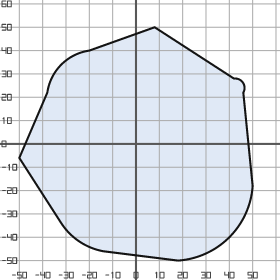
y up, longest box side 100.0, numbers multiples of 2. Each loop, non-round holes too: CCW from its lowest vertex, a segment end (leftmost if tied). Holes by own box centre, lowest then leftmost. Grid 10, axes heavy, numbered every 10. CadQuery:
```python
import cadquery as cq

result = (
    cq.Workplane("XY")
    .moveTo(18.0, -50.0)
    .threePointArc((40.0, -40.0), (50.0, -18.0))
    .lineTo(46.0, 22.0)
    .threePointArc((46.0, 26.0), (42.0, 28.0))
    .lineTo(8.0, 50.0)
    .lineTo(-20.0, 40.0)
    .threePointArc((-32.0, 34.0), (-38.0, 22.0))
    .lineTo(-50.0, -6.0)
    .lineTo(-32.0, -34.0)
    .threePointArc((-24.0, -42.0), (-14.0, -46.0))
    .close()
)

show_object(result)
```